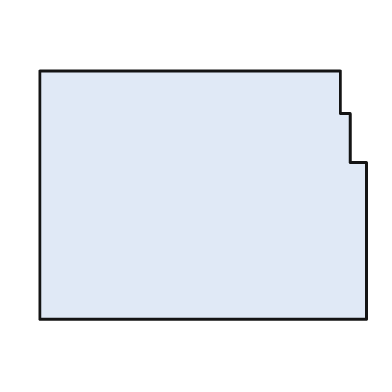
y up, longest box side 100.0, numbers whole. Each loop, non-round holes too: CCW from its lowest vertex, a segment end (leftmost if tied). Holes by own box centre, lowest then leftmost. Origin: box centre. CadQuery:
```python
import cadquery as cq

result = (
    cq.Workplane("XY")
    .moveTo(-50.0, -38.0)
    .lineTo(50.0, -38.0)
    .lineTo(50.0, 10.0)
    .lineTo(45.0, 10.0)
    .lineTo(45.0, 25.0)
    .lineTo(42.0, 25.0)
    .lineTo(42.0, 38.0)
    .lineTo(-50.0, 38.0)
    .close()
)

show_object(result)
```